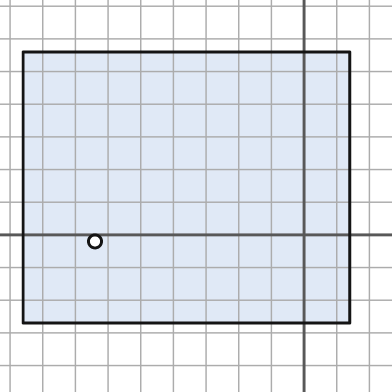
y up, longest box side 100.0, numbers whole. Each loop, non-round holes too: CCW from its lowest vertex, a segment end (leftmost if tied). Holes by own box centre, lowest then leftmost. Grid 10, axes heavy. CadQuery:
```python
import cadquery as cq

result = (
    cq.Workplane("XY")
    .moveTo(-86.0, -27.0)
    .lineTo(14.0, -27.0)
    .lineTo(14.0, 56.0)
    .lineTo(-86.0, 56.0)
    .close()
    .moveTo(-64.0, -2.0)
    .circle(2.0)
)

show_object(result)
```